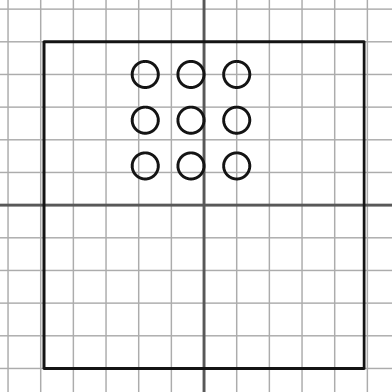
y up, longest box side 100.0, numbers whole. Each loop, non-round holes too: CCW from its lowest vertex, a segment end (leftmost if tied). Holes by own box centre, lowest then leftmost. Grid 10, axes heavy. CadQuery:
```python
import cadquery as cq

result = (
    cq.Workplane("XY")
    .moveTo(-49.0, -50.0)
    .lineTo(49.0, -50.0)
    .lineTo(49.0, 50.0)
    .lineTo(-49.0, 50.0)
    .close()
    .moveTo(-18.0, 12.0)
    .circle(4.0)
    .moveTo(-4.0, 12.0)
    .circle(4.0)
    .moveTo(10.0, 12.0)
    .circle(4.0)
    .moveTo(-18.0, 26.0)
    .circle(4.0)
    .moveTo(-4.0, 26.0)
    .circle(4.0)
    .moveTo(10.0, 26.0)
    .circle(4.0)
    .moveTo(-18.0, 40.0)
    .circle(4.0)
    .moveTo(-4.0, 40.0)
    .circle(4.0)
    .moveTo(10.0, 40.0)
    .circle(4.0)
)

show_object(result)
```